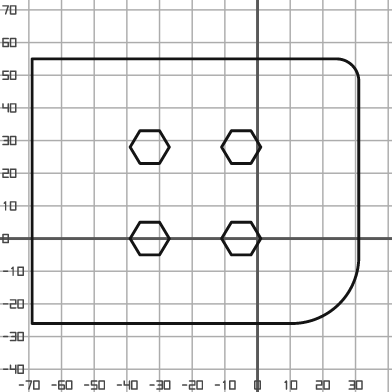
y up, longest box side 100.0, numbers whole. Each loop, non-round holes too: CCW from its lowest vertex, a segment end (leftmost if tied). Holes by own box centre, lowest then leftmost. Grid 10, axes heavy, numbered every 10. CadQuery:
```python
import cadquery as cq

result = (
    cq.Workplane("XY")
    .moveTo(-69.0, -26.0)
    .lineTo(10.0, -26.0)
    .threePointArc((25.0, -20.0), (31.0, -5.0))
    .lineTo(31.0, 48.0)
    .threePointArc((29.0, 53.0), (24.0, 55.0))
    .lineTo(-69.0, 55.0)
    .close()
    .moveTo(-36.0, -5.0)
    .lineTo(-30.0, -5.0)
    .lineTo(-27.0, 0.0)
    .lineTo(-30.0, 5.0)
    .lineTo(-36.0, 5.0)
    .lineTo(-39.0, 0.0)
    .close()
    .moveTo(-8.0, -5.0)
    .lineTo(-2.0, -5.0)
    .lineTo(1.0, 0.0)
    .lineTo(-2.0, 5.0)
    .lineTo(-8.0, 5.0)
    .lineTo(-11.0, 0.0)
    .close()
    .moveTo(-36.0, 23.0)
    .lineTo(-30.0, 23.0)
    .lineTo(-27.0, 28.0)
    .lineTo(-30.0, 33.0)
    .lineTo(-36.0, 33.0)
    .lineTo(-39.0, 28.0)
    .close()
    .moveTo(-8.0, 23.0)
    .lineTo(-2.0, 23.0)
    .lineTo(1.0, 28.0)
    .lineTo(-2.0, 33.0)
    .lineTo(-8.0, 33.0)
    .lineTo(-11.0, 28.0)
    .close()
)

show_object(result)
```